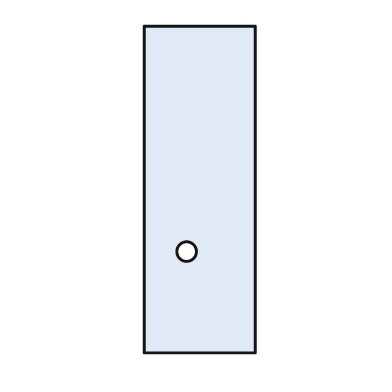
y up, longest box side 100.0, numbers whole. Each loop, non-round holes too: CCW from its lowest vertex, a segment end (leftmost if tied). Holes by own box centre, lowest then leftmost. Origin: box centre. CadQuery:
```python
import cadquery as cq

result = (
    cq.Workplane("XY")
    .moveTo(-17.0, -50.0)
    .lineTo(17.0, -50.0)
    .lineTo(17.0, 50.0)
    .lineTo(-17.0, 50.0)
    .close()
    .moveTo(-4.0, -19.0)
    .circle(3.0)
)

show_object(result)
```